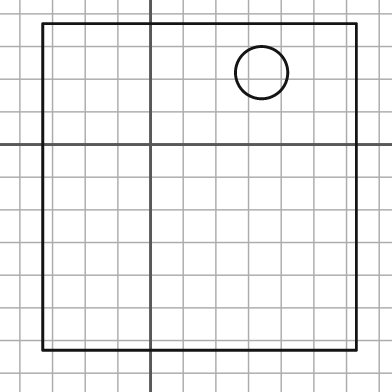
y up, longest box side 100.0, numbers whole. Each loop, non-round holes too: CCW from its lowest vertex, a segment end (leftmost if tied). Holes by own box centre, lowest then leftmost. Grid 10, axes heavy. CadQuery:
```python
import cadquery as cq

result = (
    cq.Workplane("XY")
    .moveTo(-33.0, -63.0)
    .lineTo(63.0, -63.0)
    .lineTo(63.0, 37.0)
    .lineTo(-33.0, 37.0)
    .close()
    .moveTo(34.0, 22.0)
    .circle(8.0)
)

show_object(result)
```